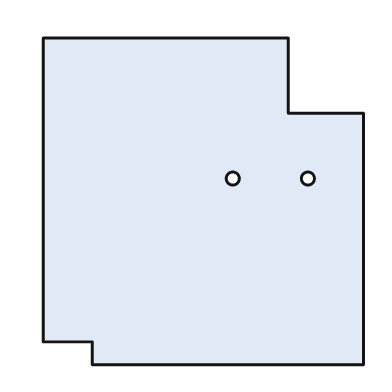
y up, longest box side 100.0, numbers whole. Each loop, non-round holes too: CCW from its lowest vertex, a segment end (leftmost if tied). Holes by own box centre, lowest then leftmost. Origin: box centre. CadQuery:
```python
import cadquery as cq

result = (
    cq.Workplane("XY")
    .moveTo(-34.0, -50.0)
    .lineTo(49.0, -50.0)
    .lineTo(49.0, 27.0)
    .lineTo(26.0, 27.0)
    .lineTo(26.0, 50.0)
    .lineTo(-49.0, 50.0)
    .lineTo(-49.0, -43.0)
    .lineTo(-34.0, -43.0)
    .close()
    .moveTo(9.0, 7.0)
    .circle(2.0)
    .moveTo(32.0, 7.0)
    .circle(2.0)
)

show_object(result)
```